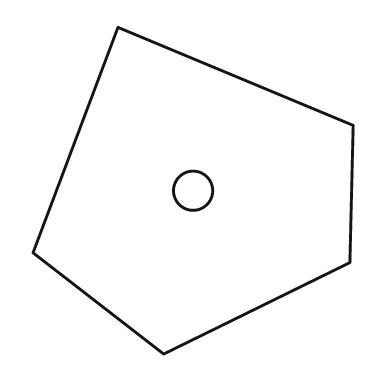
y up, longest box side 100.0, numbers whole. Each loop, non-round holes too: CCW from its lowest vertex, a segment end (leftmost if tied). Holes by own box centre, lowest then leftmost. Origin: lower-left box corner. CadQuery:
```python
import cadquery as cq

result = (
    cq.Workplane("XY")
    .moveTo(40.0, 0.0)
    .lineTo(97.0, 28.0)
    .lineTo(98.0, 70.0)
    .lineTo(26.0, 100.0)
    .lineTo(0.0, 31.0)
    .close()
    .moveTo(49.0, 50.0)
    .circle(6.0)
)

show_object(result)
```